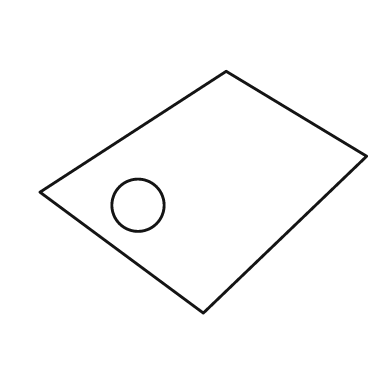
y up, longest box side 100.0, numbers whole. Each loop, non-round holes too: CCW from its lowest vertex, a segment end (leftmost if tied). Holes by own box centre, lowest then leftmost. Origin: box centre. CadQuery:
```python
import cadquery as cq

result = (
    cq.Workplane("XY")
    .moveTo(0.0, -37.0)
    .lineTo(50.0, 11.0)
    .lineTo(7.0, 37.0)
    .lineTo(-50.0, 0.0)
    .close()
    .moveTo(-20.0, -4.0)
    .circle(8.0)
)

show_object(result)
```